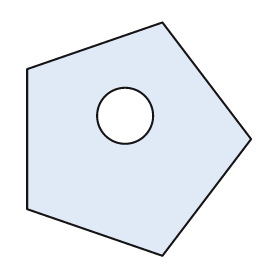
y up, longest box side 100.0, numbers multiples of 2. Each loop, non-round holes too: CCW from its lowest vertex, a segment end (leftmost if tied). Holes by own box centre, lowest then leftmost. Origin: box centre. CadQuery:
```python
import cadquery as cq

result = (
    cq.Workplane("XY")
    .moveTo(10.0, -50.0)
    .lineTo(48.0, 0.0)
    .lineTo(10.0, 50.0)
    .lineTo(-48.0, 30.0)
    .lineTo(-48.0, -30.0)
    .close()
    .moveTo(-6.0, 10.0)
    .circle(12.0)
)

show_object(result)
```